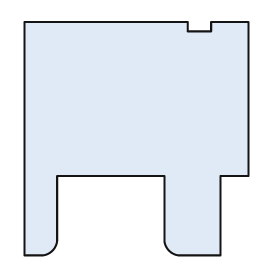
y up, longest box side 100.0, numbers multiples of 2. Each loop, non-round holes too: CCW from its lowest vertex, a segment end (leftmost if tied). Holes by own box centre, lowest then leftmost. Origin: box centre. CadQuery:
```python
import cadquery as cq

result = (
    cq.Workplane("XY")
    .moveTo(-48.0, -50.0)
    .lineTo(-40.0, -50.0)
    .threePointArc((-36.0, -48.0), (-34.0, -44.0))
    .lineTo(-34.0, -16.0)
    .lineTo(12.0, -16.0)
    .lineTo(12.0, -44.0)
    .threePointArc((14.0, -48.0), (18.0, -50.0))
    .lineTo(36.0, -50.0)
    .lineTo(36.0, -16.0)
    .lineTo(48.0, -16.0)
    .lineTo(48.0, 50.0)
    .lineTo(32.0, 50.0)
    .lineTo(32.0, 46.0)
    .lineTo(22.0, 46.0)
    .lineTo(22.0, 50.0)
    .lineTo(-48.0, 50.0)
    .close()
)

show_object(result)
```